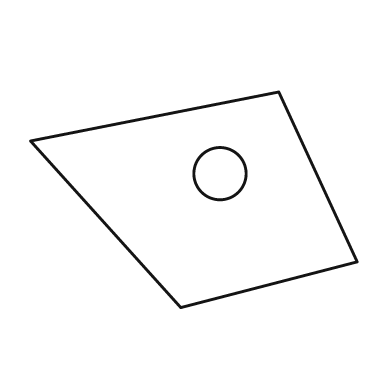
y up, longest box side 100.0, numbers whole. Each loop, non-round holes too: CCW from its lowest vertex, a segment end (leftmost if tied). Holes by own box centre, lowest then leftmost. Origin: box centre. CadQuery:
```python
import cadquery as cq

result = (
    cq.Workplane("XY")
    .moveTo(-4.0, -33.0)
    .lineTo(50.0, -19.0)
    .lineTo(26.0, 33.0)
    .lineTo(-50.0, 18.0)
    .close()
    .moveTo(8.0, 8.0)
    .circle(8.0)
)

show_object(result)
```